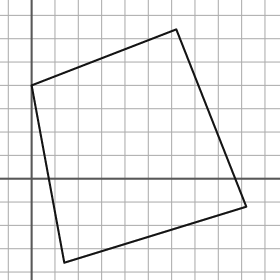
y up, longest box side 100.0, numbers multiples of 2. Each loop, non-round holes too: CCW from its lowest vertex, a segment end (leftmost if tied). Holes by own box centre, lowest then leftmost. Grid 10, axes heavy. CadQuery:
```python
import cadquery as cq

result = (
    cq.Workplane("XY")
    .moveTo(14.0, -36.0)
    .lineTo(92.0, -12.0)
    .lineTo(62.0, 64.0)
    .lineTo(0.0, 40.0)
    .close()
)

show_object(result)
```